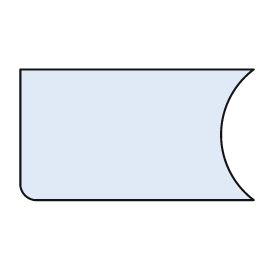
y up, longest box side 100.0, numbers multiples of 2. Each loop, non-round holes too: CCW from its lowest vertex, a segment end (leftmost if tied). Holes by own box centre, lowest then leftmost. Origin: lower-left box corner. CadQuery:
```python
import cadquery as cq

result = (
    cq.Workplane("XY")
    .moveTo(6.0, 0.0)
    .lineTo(100.0, 0.0)
    .threePointArc((86.0, 28.0), (100.0, 56.0))
    .lineTo(0.0, 56.0)
    .lineTo(0.0, 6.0)
    .threePointArc((2.0, 2.0), (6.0, 0.0))
    .close()
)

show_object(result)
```